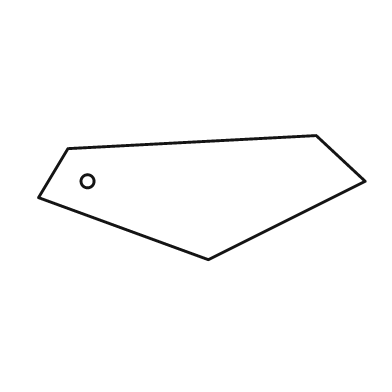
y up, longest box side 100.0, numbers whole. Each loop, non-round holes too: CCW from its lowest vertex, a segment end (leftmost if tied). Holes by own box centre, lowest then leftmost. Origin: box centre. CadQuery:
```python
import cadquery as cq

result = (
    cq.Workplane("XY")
    .moveTo(2.0, -19.0)
    .lineTo(50.0, 5.0)
    .lineTo(35.0, 19.0)
    .lineTo(-41.0, 15.0)
    .lineTo(-50.0, 0.0)
    .close()
    .moveTo(-35.0, 5.0)
    .circle(2.0)
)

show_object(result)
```